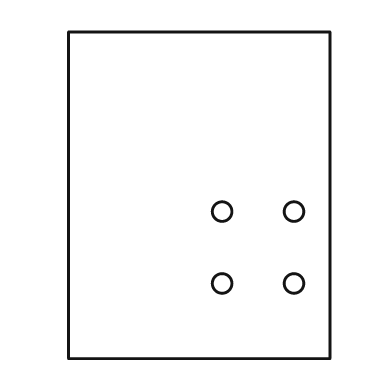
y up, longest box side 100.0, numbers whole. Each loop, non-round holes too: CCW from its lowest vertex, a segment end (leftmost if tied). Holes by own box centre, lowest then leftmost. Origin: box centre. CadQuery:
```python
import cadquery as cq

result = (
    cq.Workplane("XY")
    .moveTo(-40.0, -50.0)
    .lineTo(40.0, -50.0)
    .lineTo(40.0, 50.0)
    .lineTo(-40.0, 50.0)
    .close()
    .moveTo(7.0, -27.0)
    .circle(3.0)
    .moveTo(29.0, -27.0)
    .circle(3.0)
    .moveTo(7.0, -5.0)
    .circle(3.0)
    .moveTo(29.0, -5.0)
    .circle(3.0)
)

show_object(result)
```